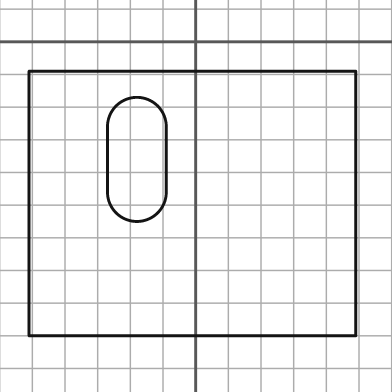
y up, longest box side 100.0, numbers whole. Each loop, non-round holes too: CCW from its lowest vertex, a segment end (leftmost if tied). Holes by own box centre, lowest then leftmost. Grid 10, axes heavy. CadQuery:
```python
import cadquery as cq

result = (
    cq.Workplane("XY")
    .moveTo(-51.0, -90.0)
    .lineTo(49.0, -90.0)
    .lineTo(49.0, -9.0)
    .lineTo(-51.0, -9.0)
    .close()
    .moveTo(-27.0, -46.0)
    .threePointArc((-18.0, -55.0), (-9.0, -46.0))
    .lineTo(-9.0, -26.0)
    .threePointArc((-18.0, -17.0), (-27.0, -26.0))
    .close()
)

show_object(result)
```